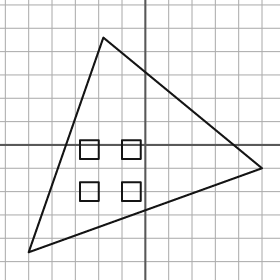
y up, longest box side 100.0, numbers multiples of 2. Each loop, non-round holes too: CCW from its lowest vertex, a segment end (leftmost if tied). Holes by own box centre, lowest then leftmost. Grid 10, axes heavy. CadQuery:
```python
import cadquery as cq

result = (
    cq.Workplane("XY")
    .moveTo(-50.0, -46.0)
    .lineTo(50.0, -10.0)
    .lineTo(-18.0, 46.0)
    .close()
    .moveTo(-28.0, -24.0)
    .lineTo(-20.0, -24.0)
    .lineTo(-20.0, -16.0)
    .lineTo(-28.0, -16.0)
    .close()
    .moveTo(-10.0, -24.0)
    .lineTo(-2.0, -24.0)
    .lineTo(-2.0, -16.0)
    .lineTo(-10.0, -16.0)
    .close()
    .moveTo(-28.0, -6.0)
    .lineTo(-20.0, -6.0)
    .lineTo(-20.0, 2.0)
    .lineTo(-28.0, 2.0)
    .close()
    .moveTo(-10.0, -6.0)
    .lineTo(-2.0, -6.0)
    .lineTo(-2.0, 2.0)
    .lineTo(-10.0, 2.0)
    .close()
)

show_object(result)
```